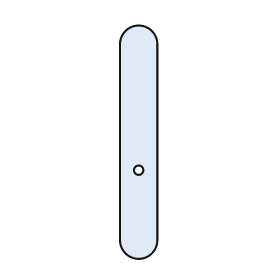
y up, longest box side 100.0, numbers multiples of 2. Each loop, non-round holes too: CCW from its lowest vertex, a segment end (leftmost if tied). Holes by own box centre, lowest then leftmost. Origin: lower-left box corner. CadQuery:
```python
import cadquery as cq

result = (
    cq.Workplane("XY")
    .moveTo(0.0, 8.0)
    .threePointArc((8.0, 0.0), (16.0, 8.0))
    .lineTo(16.0, 92.0)
    .threePointArc((8.0, 100.0), (0.0, 92.0))
    .close()
    .moveTo(8.0, 38.0)
    .circle(2.0)
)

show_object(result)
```